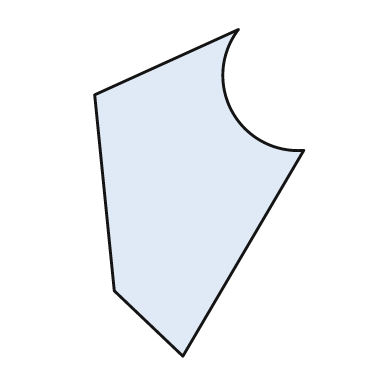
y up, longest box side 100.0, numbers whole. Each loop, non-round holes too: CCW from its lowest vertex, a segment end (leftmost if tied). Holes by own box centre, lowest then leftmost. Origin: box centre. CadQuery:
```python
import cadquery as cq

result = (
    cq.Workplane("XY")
    .moveTo(-5.0, -50.0)
    .lineTo(32.0, 13.0)
    .threePointArc((10.0, 25.0), (12.0, 50.0))
    .lineTo(-32.0, 30.0)
    .lineTo(-26.0, -30.0)
    .close()
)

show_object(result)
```